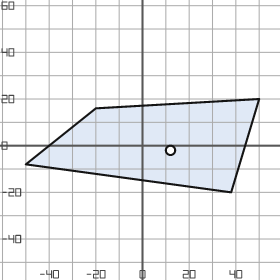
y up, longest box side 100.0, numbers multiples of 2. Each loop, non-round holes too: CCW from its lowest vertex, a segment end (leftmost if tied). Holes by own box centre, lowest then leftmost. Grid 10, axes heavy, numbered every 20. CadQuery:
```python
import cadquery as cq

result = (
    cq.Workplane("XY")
    .moveTo(38.0, -20.0)
    .lineTo(50.0, 20.0)
    .lineTo(-20.0, 16.0)
    .lineTo(-50.0, -8.0)
    .close()
    .moveTo(12.0, -2.0)
    .circle(2.0)
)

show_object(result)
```